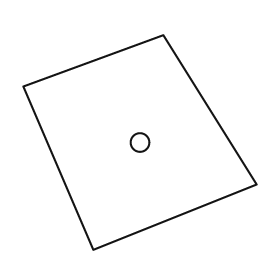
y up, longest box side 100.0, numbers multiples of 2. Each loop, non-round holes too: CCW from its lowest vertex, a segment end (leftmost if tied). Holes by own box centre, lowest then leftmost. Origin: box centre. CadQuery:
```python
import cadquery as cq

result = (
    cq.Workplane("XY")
    .moveTo(-20.0, -46.0)
    .lineTo(50.0, -18.0)
    .lineTo(10.0, 46.0)
    .lineTo(-50.0, 24.0)
    .close()
    .moveTo(0.0, 0.0)
    .circle(4.0)
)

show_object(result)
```